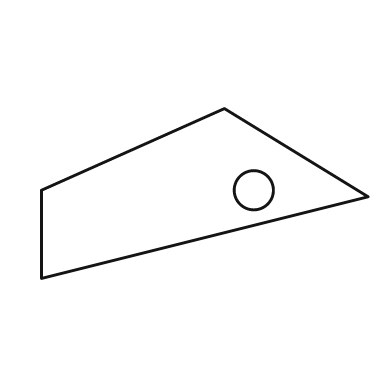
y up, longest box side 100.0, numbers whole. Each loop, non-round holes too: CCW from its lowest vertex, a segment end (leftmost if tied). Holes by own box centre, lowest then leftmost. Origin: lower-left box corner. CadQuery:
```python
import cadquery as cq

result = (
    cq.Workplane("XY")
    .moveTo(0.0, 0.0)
    .lineTo(100.0, 25.0)
    .lineTo(56.0, 52.0)
    .lineTo(0.0, 27.0)
    .close()
    .moveTo(65.0, 27.0)
    .circle(6.0)
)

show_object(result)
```